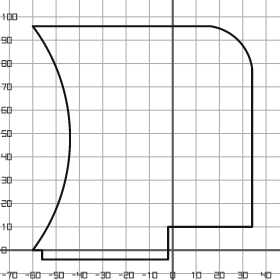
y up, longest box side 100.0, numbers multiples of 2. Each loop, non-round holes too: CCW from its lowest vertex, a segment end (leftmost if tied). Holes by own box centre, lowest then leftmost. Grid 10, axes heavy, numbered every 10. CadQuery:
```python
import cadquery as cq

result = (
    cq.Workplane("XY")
    .moveTo(-56.0, -4.0)
    .lineTo(-2.0, -4.0)
    .lineTo(-2.0, 10.0)
    .lineTo(34.0, 10.0)
    .lineTo(34.0, 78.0)
    .threePointArc((28.0, 90.0), (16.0, 96.0))
    .lineTo(-60.0, 96.0)
    .threePointArc((-44.0, 48.0), (-60.0, 0.0))
    .lineTo(-56.0, 0.0)
    .close()
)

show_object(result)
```